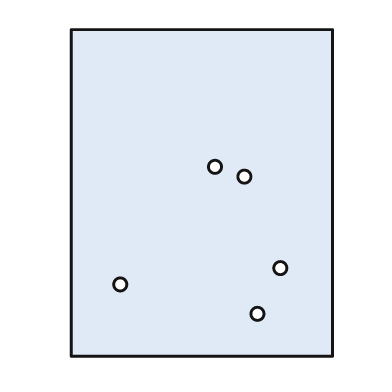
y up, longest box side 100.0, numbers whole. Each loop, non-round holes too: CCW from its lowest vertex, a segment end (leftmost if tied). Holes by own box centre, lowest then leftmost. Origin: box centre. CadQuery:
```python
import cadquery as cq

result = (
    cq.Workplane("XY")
    .moveTo(-40.0, -50.0)
    .lineTo(40.0, -50.0)
    .lineTo(40.0, 50.0)
    .lineTo(-40.0, 50.0)
    .close()
    .moveTo(17.0, -37.0)
    .circle(2.0)
    .moveTo(-25.0, -28.0)
    .circle(2.0)
    .moveTo(24.0, -23.0)
    .circle(2.0)
    .moveTo(13.0, 5.0)
    .circle(2.0)
    .moveTo(4.0, 8.0)
    .circle(2.0)
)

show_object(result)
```